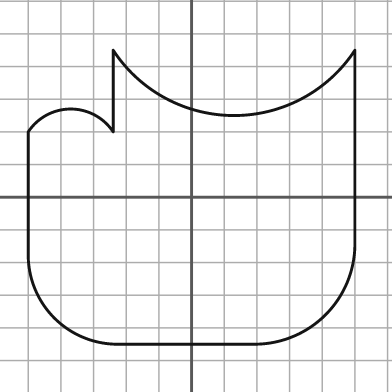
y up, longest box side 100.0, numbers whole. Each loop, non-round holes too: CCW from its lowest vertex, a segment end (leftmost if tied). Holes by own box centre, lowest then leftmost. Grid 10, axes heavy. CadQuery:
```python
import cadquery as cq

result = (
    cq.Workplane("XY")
    .moveTo(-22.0, -45.0)
    .lineTo(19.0, -45.0)
    .threePointArc((41.0, -36.0), (50.0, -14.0))
    .lineTo(50.0, 45.0)
    .threePointArc((13.0, 25.0), (-24.0, 45.0))
    .lineTo(-24.0, 20.0)
    .threePointArc((-37.0, 27.0), (-50.0, 20.0))
    .lineTo(-50.0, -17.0)
    .threePointArc((-42.0, -37.0), (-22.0, -45.0))
    .close()
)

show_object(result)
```